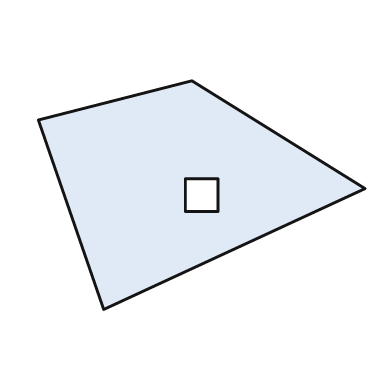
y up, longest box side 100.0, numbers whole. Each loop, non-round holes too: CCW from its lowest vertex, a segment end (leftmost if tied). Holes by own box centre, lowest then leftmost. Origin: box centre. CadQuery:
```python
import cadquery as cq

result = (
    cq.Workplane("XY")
    .moveTo(-30.0, -35.0)
    .lineTo(50.0, 2.0)
    .lineTo(-3.0, 35.0)
    .lineTo(-50.0, 23.0)
    .close()
    .moveTo(-5.0, -5.0)
    .lineTo(5.0, -5.0)
    .lineTo(5.0, 5.0)
    .lineTo(-5.0, 5.0)
    .close()
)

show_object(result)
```